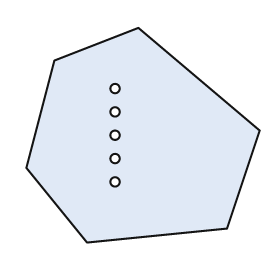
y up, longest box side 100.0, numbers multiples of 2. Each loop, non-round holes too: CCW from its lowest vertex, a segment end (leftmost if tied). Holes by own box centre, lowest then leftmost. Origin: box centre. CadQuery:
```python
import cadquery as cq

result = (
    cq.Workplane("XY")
    .moveTo(-24.0, -46.0)
    .lineTo(36.0, -40.0)
    .lineTo(50.0, 2.0)
    .lineTo(-2.0, 46.0)
    .lineTo(-38.0, 32.0)
    .lineTo(-50.0, -14.0)
    .close()
    .moveTo(-12.0, -20.0)
    .circle(2.0)
    .moveTo(-12.0, -10.0)
    .circle(2.0)
    .moveTo(-12.0, 0.0)
    .circle(2.0)
    .moveTo(-12.0, 10.0)
    .circle(2.0)
    .moveTo(-12.0, 20.0)
    .circle(2.0)
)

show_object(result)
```